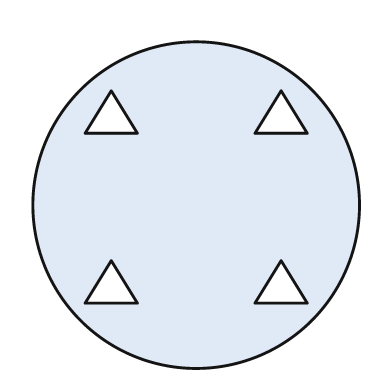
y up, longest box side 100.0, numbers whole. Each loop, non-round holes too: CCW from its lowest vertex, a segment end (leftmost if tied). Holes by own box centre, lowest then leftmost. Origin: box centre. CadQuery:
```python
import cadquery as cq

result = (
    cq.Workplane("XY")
    .moveTo(0.0, 0.0)
    .circle(50.0)
    .moveTo(-34.0, -30.0)
    .lineTo(-18.0, -30.0)
    .lineTo(-26.0, -17.0)
    .close()
    .moveTo(18.0, -30.0)
    .lineTo(34.0, -30.0)
    .lineTo(26.0, -17.0)
    .close()
    .moveTo(-34.0, 22.0)
    .lineTo(-18.0, 22.0)
    .lineTo(-26.0, 35.0)
    .close()
    .moveTo(18.0, 22.0)
    .lineTo(34.0, 22.0)
    .lineTo(26.0, 35.0)
    .close()
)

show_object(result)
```